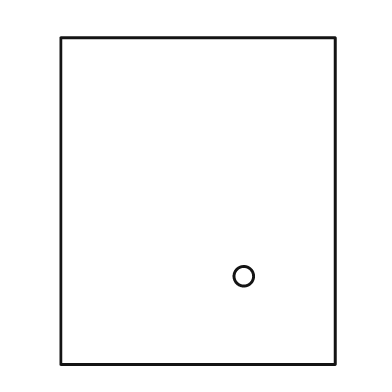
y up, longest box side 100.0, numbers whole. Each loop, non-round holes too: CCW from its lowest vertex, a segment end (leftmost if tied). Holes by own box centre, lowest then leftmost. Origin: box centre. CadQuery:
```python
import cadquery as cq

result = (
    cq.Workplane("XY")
    .moveTo(-42.0, -50.0)
    .lineTo(42.0, -50.0)
    .lineTo(42.0, 50.0)
    .lineTo(-42.0, 50.0)
    .close()
    .moveTo(14.0, -23.0)
    .circle(3.0)
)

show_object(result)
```